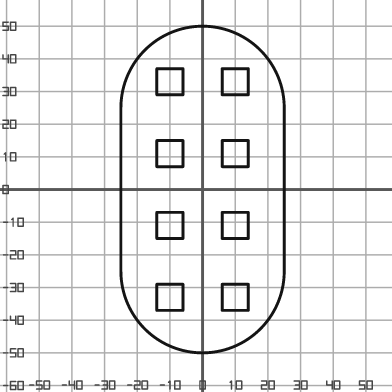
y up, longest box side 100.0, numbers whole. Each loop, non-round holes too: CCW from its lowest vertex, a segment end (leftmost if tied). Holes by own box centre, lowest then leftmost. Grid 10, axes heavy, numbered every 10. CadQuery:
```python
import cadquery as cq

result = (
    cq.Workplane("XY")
    .moveTo(-25.0, -25.0)
    .threePointArc((0.0, -50.0), (25.0, -25.0))
    .lineTo(25.0, 25.0)
    .threePointArc((0.0, 50.0), (-25.0, 25.0))
    .close()
    .moveTo(-14.0, -37.0)
    .lineTo(-6.0, -37.0)
    .lineTo(-6.0, -29.0)
    .lineTo(-14.0, -29.0)
    .close()
    .moveTo(6.0, -37.0)
    .lineTo(14.0, -37.0)
    .lineTo(14.0, -29.0)
    .lineTo(6.0, -29.0)
    .close()
    .moveTo(-14.0, -15.0)
    .lineTo(-6.0, -15.0)
    .lineTo(-6.0, -7.0)
    .lineTo(-14.0, -7.0)
    .close()
    .moveTo(6.0, -15.0)
    .lineTo(14.0, -15.0)
    .lineTo(14.0, -7.0)
    .lineTo(6.0, -7.0)
    .close()
    .moveTo(-14.0, 7.0)
    .lineTo(-6.0, 7.0)
    .lineTo(-6.0, 15.0)
    .lineTo(-14.0, 15.0)
    .close()
    .moveTo(6.0, 7.0)
    .lineTo(14.0, 7.0)
    .lineTo(14.0, 15.0)
    .lineTo(6.0, 15.0)
    .close()
    .moveTo(-14.0, 29.0)
    .lineTo(-6.0, 29.0)
    .lineTo(-6.0, 37.0)
    .lineTo(-14.0, 37.0)
    .close()
    .moveTo(6.0, 29.0)
    .lineTo(14.0, 29.0)
    .lineTo(14.0, 37.0)
    .lineTo(6.0, 37.0)
    .close()
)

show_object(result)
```